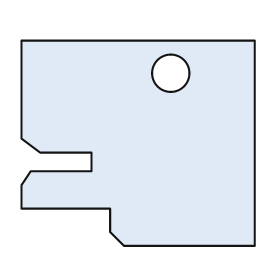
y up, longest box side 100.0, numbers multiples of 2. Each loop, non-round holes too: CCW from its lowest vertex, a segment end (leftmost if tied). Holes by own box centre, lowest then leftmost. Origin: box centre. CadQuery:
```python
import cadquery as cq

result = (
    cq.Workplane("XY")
    .moveTo(-6.0, -44.0)
    .lineTo(50.0, -44.0)
    .lineTo(50.0, 44.0)
    .lineTo(-50.0, 44.0)
    .lineTo(-50.0, 2.0)
    .lineTo(-42.0, -4.0)
    .lineTo(-20.0, -4.0)
    .lineTo(-20.0, -12.0)
    .lineTo(-46.0, -12.0)
    .lineTo(-50.0, -18.0)
    .lineTo(-50.0, -28.0)
    .lineTo(-12.0, -28.0)
    .lineTo(-12.0, -38.0)
    .close()
    .moveTo(14.0, 30.0)
    .circle(8.0)
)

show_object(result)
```